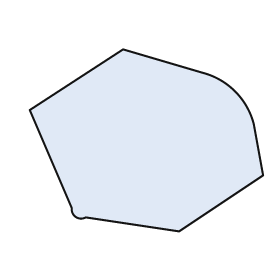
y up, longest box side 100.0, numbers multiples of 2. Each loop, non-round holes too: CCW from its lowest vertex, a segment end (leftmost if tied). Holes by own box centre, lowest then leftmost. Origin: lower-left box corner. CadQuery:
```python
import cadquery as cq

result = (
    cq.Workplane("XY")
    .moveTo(64.0, 0.0)
    .lineTo(100.0, 24.0)
    .lineTo(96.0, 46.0)
    .threePointArc((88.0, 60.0), (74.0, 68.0))
    .lineTo(40.0, 78.0)
    .lineTo(0.0, 52.0)
    .lineTo(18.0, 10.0)
    .threePointArc((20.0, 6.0), (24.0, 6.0))
    .close()
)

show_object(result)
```